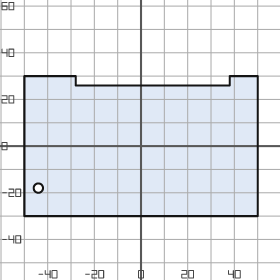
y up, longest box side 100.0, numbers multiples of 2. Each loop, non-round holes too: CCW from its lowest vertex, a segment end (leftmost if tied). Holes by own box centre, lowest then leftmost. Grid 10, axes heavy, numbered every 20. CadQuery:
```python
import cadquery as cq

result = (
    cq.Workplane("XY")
    .moveTo(-50.0, -30.0)
    .lineTo(50.0, -30.0)
    .lineTo(50.0, 30.0)
    .lineTo(38.0, 30.0)
    .lineTo(38.0, 26.0)
    .lineTo(-28.0, 26.0)
    .lineTo(-28.0, 30.0)
    .lineTo(-50.0, 30.0)
    .close()
    .moveTo(-44.0, -18.0)
    .circle(2.0)
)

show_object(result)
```